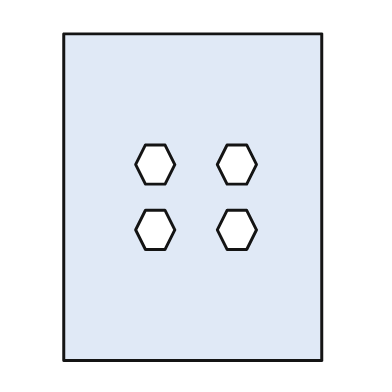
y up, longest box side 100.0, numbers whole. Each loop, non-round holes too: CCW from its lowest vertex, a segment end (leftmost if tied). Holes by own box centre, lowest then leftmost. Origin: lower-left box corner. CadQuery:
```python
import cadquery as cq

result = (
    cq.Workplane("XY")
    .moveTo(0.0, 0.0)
    .lineTo(79.0, 0.0)
    .lineTo(79.0, 100.0)
    .lineTo(0.0, 100.0)
    .close()
    .moveTo(25.0, 34.0)
    .lineTo(31.0, 34.0)
    .lineTo(34.0, 40.0)
    .lineTo(31.0, 46.0)
    .lineTo(25.0, 46.0)
    .lineTo(22.0, 40.0)
    .close()
    .moveTo(50.0, 34.0)
    .lineTo(56.0, 34.0)
    .lineTo(59.0, 40.0)
    .lineTo(56.0, 46.0)
    .lineTo(50.0, 46.0)
    .lineTo(47.0, 40.0)
    .close()
    .moveTo(25.0, 54.0)
    .lineTo(31.0, 54.0)
    .lineTo(34.0, 60.0)
    .lineTo(31.0, 66.0)
    .lineTo(25.0, 66.0)
    .lineTo(22.0, 60.0)
    .close()
    .moveTo(50.0, 54.0)
    .lineTo(56.0, 54.0)
    .lineTo(59.0, 60.0)
    .lineTo(56.0, 66.0)
    .lineTo(50.0, 66.0)
    .lineTo(47.0, 60.0)
    .close()
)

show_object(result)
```